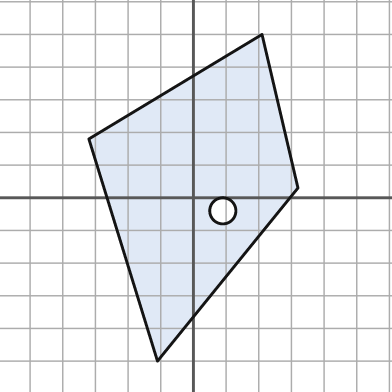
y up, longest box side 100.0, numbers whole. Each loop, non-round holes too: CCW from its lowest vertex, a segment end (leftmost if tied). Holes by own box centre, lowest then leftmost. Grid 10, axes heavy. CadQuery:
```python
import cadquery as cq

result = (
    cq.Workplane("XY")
    .moveTo(-11.0, -50.0)
    .lineTo(32.0, 3.0)
    .lineTo(21.0, 50.0)
    .lineTo(-32.0, 18.0)
    .close()
    .moveTo(9.0, -4.0)
    .circle(4.0)
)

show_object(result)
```